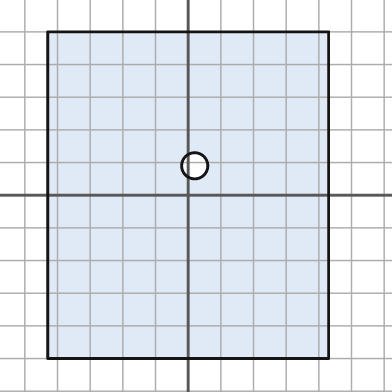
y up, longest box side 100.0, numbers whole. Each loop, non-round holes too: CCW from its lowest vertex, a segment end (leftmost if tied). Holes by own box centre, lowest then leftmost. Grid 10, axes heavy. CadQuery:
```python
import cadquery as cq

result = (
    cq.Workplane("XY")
    .moveTo(-43.0, -50.0)
    .lineTo(43.0, -50.0)
    .lineTo(43.0, 50.0)
    .lineTo(-43.0, 50.0)
    .close()
    .moveTo(2.0, 9.0)
    .circle(4.0)
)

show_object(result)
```